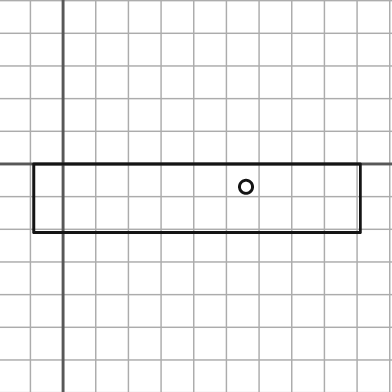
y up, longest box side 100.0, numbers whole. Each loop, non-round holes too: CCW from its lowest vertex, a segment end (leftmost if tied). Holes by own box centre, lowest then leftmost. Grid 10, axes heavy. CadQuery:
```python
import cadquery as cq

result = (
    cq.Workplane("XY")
    .moveTo(-9.0, -21.0)
    .lineTo(91.0, -21.0)
    .lineTo(91.0, 0.0)
    .lineTo(-9.0, 0.0)
    .close()
    .moveTo(56.0, -7.0)
    .circle(2.0)
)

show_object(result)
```